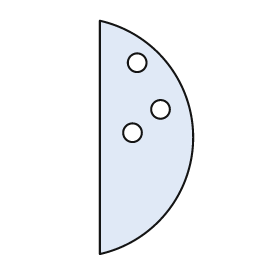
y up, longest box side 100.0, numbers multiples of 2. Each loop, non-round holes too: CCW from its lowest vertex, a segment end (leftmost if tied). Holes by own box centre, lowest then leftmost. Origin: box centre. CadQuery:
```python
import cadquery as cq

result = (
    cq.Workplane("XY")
    .moveTo(-20.0, -50.0)
    .threePointArc((20.0, 0.0), (-20.0, 50.0))
    .close()
    .moveTo(-6.0, 2.0)
    .circle(4.0)
    .moveTo(6.0, 12.0)
    .circle(4.0)
    .moveTo(-4.0, 32.0)
    .circle(4.0)
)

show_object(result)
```